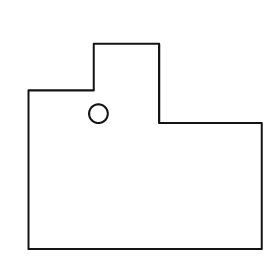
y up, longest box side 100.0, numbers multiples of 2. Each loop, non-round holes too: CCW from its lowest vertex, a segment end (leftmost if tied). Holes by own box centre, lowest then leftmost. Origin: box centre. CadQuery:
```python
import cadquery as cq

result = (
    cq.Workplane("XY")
    .moveTo(-50.0, -44.0)
    .lineTo(50.0, -44.0)
    .lineTo(50.0, 10.0)
    .lineTo(6.0, 10.0)
    .lineTo(6.0, 44.0)
    .lineTo(-22.0, 44.0)
    .lineTo(-22.0, 24.0)
    .lineTo(-50.0, 24.0)
    .close()
    .moveTo(-20.0, 14.0)
    .circle(4.0)
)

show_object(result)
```